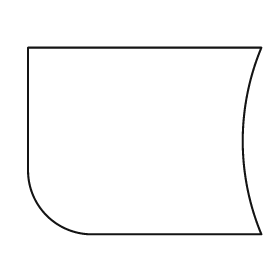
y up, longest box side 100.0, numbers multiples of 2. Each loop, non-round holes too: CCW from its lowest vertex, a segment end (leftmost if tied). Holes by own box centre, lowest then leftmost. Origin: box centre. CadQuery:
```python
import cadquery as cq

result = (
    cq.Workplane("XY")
    .moveTo(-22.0, -40.0)
    .lineTo(50.0, -40.0)
    .threePointArc((42.0, 0.0), (50.0, 40.0))
    .lineTo(-50.0, 40.0)
    .lineTo(-50.0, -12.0)
    .threePointArc((-42.0, -32.0), (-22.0, -40.0))
    .close()
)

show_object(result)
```